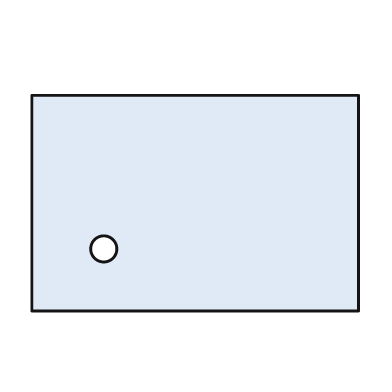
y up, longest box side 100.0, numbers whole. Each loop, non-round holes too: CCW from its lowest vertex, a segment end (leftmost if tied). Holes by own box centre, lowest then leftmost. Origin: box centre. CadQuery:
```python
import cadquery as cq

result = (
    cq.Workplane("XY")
    .moveTo(-50.0, -33.0)
    .lineTo(50.0, -33.0)
    .lineTo(50.0, 33.0)
    .lineTo(-50.0, 33.0)
    .close()
    .moveTo(-28.0, -14.0)
    .circle(4.0)
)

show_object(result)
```